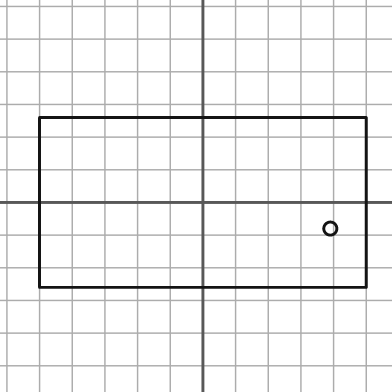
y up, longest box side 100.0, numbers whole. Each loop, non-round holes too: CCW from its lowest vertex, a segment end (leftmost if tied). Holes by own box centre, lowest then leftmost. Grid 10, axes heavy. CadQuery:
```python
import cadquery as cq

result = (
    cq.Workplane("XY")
    .moveTo(-50.0, -26.0)
    .lineTo(50.0, -26.0)
    .lineTo(50.0, 26.0)
    .lineTo(-50.0, 26.0)
    .close()
    .moveTo(39.0, -8.0)
    .circle(2.0)
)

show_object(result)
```